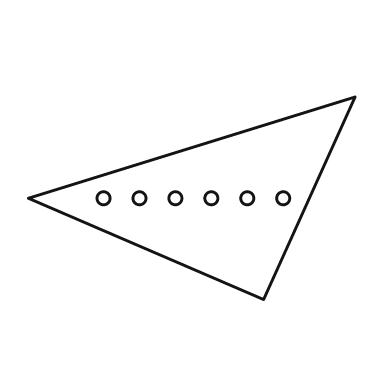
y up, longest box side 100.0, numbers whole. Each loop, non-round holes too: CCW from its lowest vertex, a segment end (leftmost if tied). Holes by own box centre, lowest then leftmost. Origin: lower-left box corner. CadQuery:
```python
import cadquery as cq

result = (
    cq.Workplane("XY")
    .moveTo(72.0, 0.0)
    .lineTo(100.0, 62.0)
    .lineTo(0.0, 31.0)
    .close()
    .moveTo(23.0, 31.0)
    .circle(2.0)
    .moveTo(34.0, 31.0)
    .circle(2.0)
    .moveTo(45.0, 31.0)
    .circle(2.0)
    .moveTo(56.0, 31.0)
    .circle(2.0)
    .moveTo(67.0, 31.0)
    .circle(2.0)
    .moveTo(78.0, 31.0)
    .circle(2.0)
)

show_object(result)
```